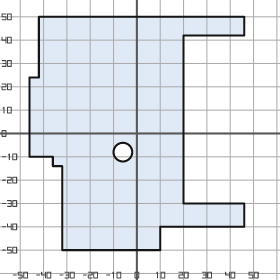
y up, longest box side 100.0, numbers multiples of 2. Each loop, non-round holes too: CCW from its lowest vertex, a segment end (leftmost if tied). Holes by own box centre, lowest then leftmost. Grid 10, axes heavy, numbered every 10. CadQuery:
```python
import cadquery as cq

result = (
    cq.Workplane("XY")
    .moveTo(-32.0, -50.0)
    .lineTo(10.0, -50.0)
    .lineTo(10.0, -40.0)
    .lineTo(46.0, -40.0)
    .lineTo(46.0, -30.0)
    .lineTo(20.0, -30.0)
    .lineTo(20.0, 42.0)
    .lineTo(46.0, 42.0)
    .lineTo(46.0, 50.0)
    .lineTo(-42.0, 50.0)
    .lineTo(-42.0, 24.0)
    .lineTo(-46.0, 24.0)
    .lineTo(-46.0, -10.0)
    .lineTo(-36.0, -10.0)
    .lineTo(-36.0, -14.0)
    .lineTo(-32.0, -14.0)
    .close()
    .moveTo(-6.0, -8.0)
    .circle(4.0)
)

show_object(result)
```